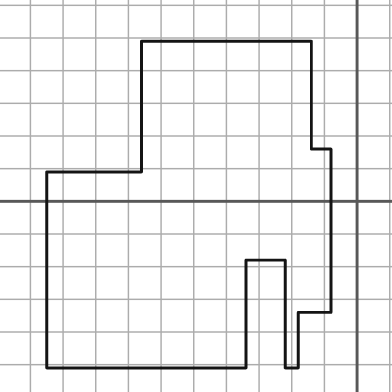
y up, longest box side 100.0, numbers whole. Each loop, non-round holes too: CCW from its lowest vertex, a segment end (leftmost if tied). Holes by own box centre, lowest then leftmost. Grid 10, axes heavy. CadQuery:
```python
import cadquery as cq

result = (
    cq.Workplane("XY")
    .moveTo(-95.0, -51.0)
    .lineTo(-34.0, -51.0)
    .lineTo(-34.0, -18.0)
    .lineTo(-22.0, -18.0)
    .lineTo(-22.0, -51.0)
    .lineTo(-18.0, -51.0)
    .lineTo(-18.0, -34.0)
    .lineTo(-8.0, -34.0)
    .lineTo(-8.0, 16.0)
    .lineTo(-14.0, 16.0)
    .lineTo(-14.0, 49.0)
    .lineTo(-66.0, 49.0)
    .lineTo(-66.0, 9.0)
    .lineTo(-95.0, 9.0)
    .close()
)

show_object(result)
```